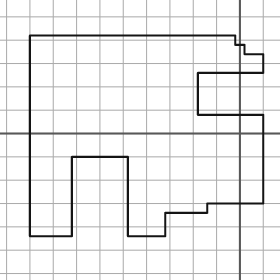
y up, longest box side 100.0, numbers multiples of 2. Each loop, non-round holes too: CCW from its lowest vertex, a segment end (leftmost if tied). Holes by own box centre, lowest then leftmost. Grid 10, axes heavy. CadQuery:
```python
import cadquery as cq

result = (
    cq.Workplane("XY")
    .moveTo(-90.0, -44.0)
    .lineTo(-72.0, -44.0)
    .lineTo(-72.0, -10.0)
    .lineTo(-48.0, -10.0)
    .lineTo(-48.0, -44.0)
    .lineTo(-32.0, -44.0)
    .lineTo(-32.0, -34.0)
    .lineTo(-14.0, -34.0)
    .lineTo(-14.0, -30.0)
    .lineTo(10.0, -30.0)
    .lineTo(10.0, 8.0)
    .lineTo(-18.0, 8.0)
    .lineTo(-18.0, 26.0)
    .lineTo(10.0, 26.0)
    .lineTo(10.0, 34.0)
    .lineTo(2.0, 34.0)
    .lineTo(2.0, 38.0)
    .lineTo(-2.0, 38.0)
    .lineTo(-2.0, 42.0)
    .lineTo(-90.0, 42.0)
    .close()
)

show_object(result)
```